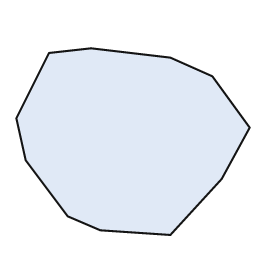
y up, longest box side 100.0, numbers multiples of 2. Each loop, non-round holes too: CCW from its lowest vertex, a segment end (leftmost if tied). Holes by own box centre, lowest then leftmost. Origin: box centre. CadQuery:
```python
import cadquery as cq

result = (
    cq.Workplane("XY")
    .moveTo(16.0, -40.0)
    .lineTo(38.0, -16.0)
    .lineTo(50.0, 6.0)
    .lineTo(34.0, 28.0)
    .lineTo(16.0, 36.0)
    .lineTo(-18.0, 40.0)
    .lineTo(-36.0, 38.0)
    .lineTo(-50.0, 10.0)
    .lineTo(-46.0, -8.0)
    .lineTo(-28.0, -32.0)
    .lineTo(-14.0, -38.0)
    .close()
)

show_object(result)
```